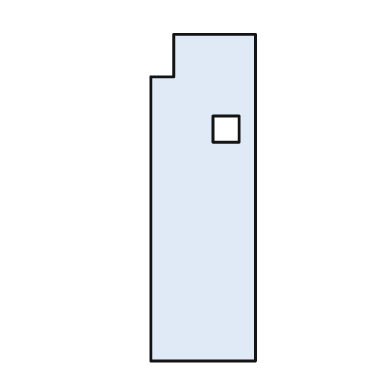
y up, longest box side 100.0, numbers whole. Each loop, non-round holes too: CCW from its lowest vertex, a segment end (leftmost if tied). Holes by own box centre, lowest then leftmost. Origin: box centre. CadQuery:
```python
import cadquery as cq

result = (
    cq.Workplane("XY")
    .moveTo(-16.0, -50.0)
    .lineTo(16.0, -50.0)
    .lineTo(16.0, 50.0)
    .lineTo(-9.0, 50.0)
    .lineTo(-9.0, 37.0)
    .lineTo(-16.0, 37.0)
    .close()
    .moveTo(3.0, 17.0)
    .lineTo(11.0, 17.0)
    .lineTo(11.0, 25.0)
    .lineTo(3.0, 25.0)
    .close()
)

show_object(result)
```